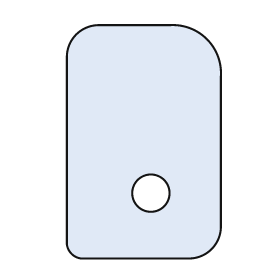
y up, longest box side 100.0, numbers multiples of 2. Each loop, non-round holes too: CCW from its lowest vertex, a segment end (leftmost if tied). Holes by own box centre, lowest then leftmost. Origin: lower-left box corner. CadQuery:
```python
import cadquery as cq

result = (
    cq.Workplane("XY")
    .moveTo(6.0, 0.0)
    .lineTo(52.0, 0.0)
    .threePointArc((62.0, 4.0), (66.0, 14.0))
    .lineTo(66.0, 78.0)
    .threePointArc((60.0, 94.0), (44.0, 100.0))
    .lineTo(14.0, 100.0)
    .threePointArc((4.0, 96.0), (0.0, 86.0))
    .lineTo(0.0, 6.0)
    .threePointArc((2.0, 2.0), (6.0, 0.0))
    .close()
    .moveTo(36.0, 28.0)
    .circle(8.0)
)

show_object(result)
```